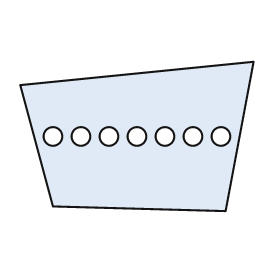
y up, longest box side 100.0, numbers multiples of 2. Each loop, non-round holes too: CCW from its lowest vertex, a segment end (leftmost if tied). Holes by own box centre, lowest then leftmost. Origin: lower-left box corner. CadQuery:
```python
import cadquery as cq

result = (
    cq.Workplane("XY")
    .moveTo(88.0, 0.0)
    .lineTo(100.0, 64.0)
    .lineTo(0.0, 54.0)
    .lineTo(14.0, 2.0)
    .close()
    .moveTo(14.0, 32.0)
    .circle(4.0)
    .moveTo(26.0, 32.0)
    .circle(4.0)
    .moveTo(38.0, 32.0)
    .circle(4.0)
    .moveTo(50.0, 32.0)
    .circle(4.0)
    .moveTo(62.0, 32.0)
    .circle(4.0)
    .moveTo(74.0, 32.0)
    .circle(4.0)
    .moveTo(86.0, 32.0)
    .circle(4.0)
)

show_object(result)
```